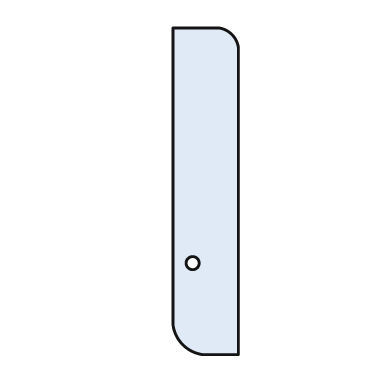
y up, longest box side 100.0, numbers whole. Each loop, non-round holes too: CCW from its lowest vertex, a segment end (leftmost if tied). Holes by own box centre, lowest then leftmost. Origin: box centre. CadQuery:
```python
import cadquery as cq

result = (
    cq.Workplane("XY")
    .moveTo(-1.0, -50.0)
    .lineTo(10.0, -50.0)
    .lineTo(10.0, 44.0)
    .threePointArc((8.0, 48.0), (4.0, 50.0))
    .lineTo(-10.0, 50.0)
    .lineTo(-10.0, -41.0)
    .threePointArc((-7.0, -47.0), (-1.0, -50.0))
    .close()
    .moveTo(-4.0, -22.0)
    .circle(2.0)
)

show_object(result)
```